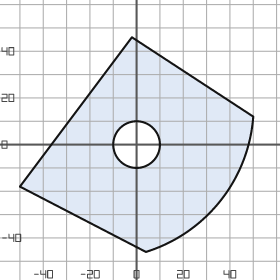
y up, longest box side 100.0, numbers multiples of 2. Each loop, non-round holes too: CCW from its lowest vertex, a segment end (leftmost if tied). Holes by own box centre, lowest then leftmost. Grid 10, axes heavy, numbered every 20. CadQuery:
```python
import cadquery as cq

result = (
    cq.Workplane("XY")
    .moveTo(4.0, -46.0)
    .threePointArc((36.0, -24.0), (50.0, 12.0))
    .lineTo(-2.0, 46.0)
    .lineTo(-50.0, -18.0)
    .close()
    .moveTo(0.0, 0.0)
    .circle(10.0)
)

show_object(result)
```